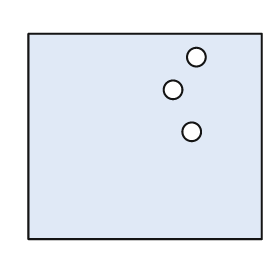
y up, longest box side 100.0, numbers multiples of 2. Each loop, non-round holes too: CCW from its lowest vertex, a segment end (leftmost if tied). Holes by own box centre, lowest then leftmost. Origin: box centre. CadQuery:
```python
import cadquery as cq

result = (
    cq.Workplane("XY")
    .moveTo(-50.0, -44.0)
    .lineTo(50.0, -44.0)
    .lineTo(50.0, 44.0)
    .lineTo(-50.0, 44.0)
    .close()
    .moveTo(20.0, 2.0)
    .circle(4.0)
    .moveTo(12.0, 20.0)
    .circle(4.0)
    .moveTo(22.0, 34.0)
    .circle(4.0)
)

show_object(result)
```